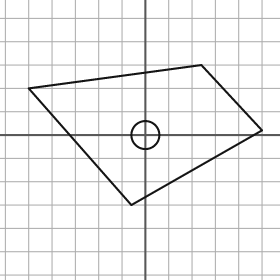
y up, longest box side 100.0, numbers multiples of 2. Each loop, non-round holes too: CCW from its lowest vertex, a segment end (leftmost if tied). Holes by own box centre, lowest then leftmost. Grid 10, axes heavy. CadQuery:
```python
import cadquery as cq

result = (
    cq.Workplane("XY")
    .moveTo(-6.0, -30.0)
    .lineTo(50.0, 2.0)
    .lineTo(24.0, 30.0)
    .lineTo(-50.0, 20.0)
    .close()
    .moveTo(0.0, 0.0)
    .circle(6.0)
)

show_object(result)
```